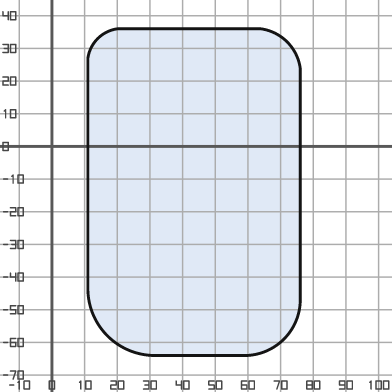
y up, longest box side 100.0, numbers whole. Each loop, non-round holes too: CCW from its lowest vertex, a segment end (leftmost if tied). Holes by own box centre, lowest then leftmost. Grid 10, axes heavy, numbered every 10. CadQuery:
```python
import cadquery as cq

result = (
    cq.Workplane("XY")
    .moveTo(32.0, -64.0)
    .lineTo(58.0, -64.0)
    .threePointArc((71.0, -59.0), (76.0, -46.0))
    .lineTo(76.0, 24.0)
    .threePointArc((72.0, 32.0), (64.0, 36.0))
    .lineTo(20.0, 36.0)
    .threePointArc((14.0, 33.0), (11.0, 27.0))
    .lineTo(11.0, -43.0)
    .threePointArc((17.0, -58.0), (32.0, -64.0))
    .close()
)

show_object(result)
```